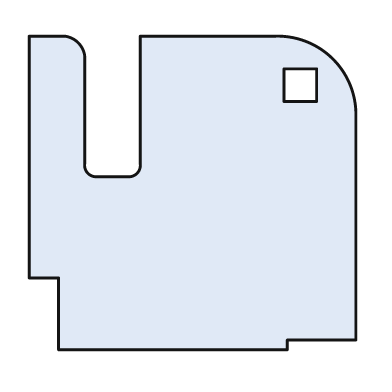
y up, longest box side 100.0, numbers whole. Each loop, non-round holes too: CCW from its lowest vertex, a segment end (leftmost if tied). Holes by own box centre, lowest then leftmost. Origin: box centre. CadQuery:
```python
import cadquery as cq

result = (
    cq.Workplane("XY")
    .moveTo(-41.0, -48.0)
    .lineTo(29.0, -48.0)
    .lineTo(29.0, -45.0)
    .lineTo(50.0, -45.0)
    .lineTo(50.0, 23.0)
    .threePointArc((43.0, 41.0), (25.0, 48.0))
    .lineTo(-16.0, 48.0)
    .lineTo(-16.0, 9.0)
    .threePointArc((-17.0, 6.0), (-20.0, 5.0))
    .lineTo(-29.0, 5.0)
    .threePointArc((-32.0, 6.0), (-33.0, 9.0))
    .lineTo(-33.0, 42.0)
    .threePointArc((-35.0, 46.0), (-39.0, 48.0))
    .lineTo(-50.0, 48.0)
    .lineTo(-50.0, -26.0)
    .lineTo(-41.0, -26.0)
    .close()
    .moveTo(28.0, 28.0)
    .lineTo(38.0, 28.0)
    .lineTo(38.0, 38.0)
    .lineTo(28.0, 38.0)
    .close()
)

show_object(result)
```